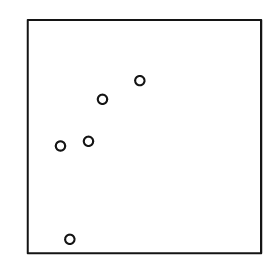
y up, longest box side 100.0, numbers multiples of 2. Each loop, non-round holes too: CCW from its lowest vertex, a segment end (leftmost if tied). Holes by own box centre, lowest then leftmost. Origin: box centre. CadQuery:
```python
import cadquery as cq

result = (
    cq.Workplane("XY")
    .moveTo(-50.0, -50.0)
    .lineTo(50.0, -50.0)
    .lineTo(50.0, 50.0)
    .lineTo(-50.0, 50.0)
    .close()
    .moveTo(-32.0, -44.0)
    .circle(2.0)
    .moveTo(-36.0, -4.0)
    .circle(2.0)
    .moveTo(-24.0, -2.0)
    .circle(2.0)
    .moveTo(-18.0, 16.0)
    .circle(2.0)
    .moveTo(-2.0, 24.0)
    .circle(2.0)
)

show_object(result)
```